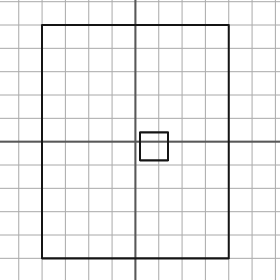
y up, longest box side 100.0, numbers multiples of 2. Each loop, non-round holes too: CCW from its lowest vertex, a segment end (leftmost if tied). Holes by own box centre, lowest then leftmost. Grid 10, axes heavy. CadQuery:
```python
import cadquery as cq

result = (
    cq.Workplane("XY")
    .moveTo(-40.0, -50.0)
    .lineTo(40.0, -50.0)
    .lineTo(40.0, 50.0)
    .lineTo(-40.0, 50.0)
    .close()
    .moveTo(2.0, -8.0)
    .lineTo(14.0, -8.0)
    .lineTo(14.0, 4.0)
    .lineTo(2.0, 4.0)
    .close()
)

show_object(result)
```